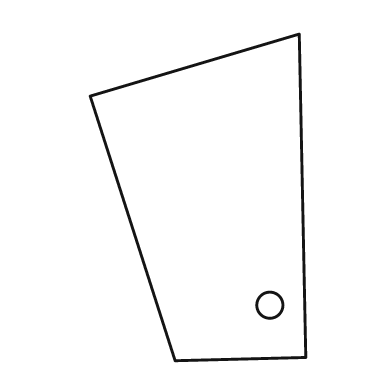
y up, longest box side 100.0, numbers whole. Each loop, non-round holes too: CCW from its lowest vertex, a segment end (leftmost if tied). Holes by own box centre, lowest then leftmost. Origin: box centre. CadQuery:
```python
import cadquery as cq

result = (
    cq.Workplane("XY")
    .moveTo(-7.0, -50.0)
    .lineTo(33.0, -49.0)
    .lineTo(31.0, 50.0)
    .lineTo(-33.0, 31.0)
    .close()
    .moveTo(22.0, -33.0)
    .circle(4.0)
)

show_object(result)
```